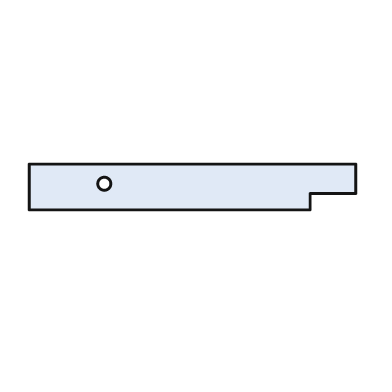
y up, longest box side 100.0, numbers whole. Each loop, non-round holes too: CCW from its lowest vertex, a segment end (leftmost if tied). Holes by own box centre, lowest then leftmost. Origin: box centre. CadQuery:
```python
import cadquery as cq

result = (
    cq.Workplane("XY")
    .moveTo(-50.0, -7.0)
    .lineTo(36.0, -7.0)
    .lineTo(36.0, -2.0)
    .lineTo(50.0, -2.0)
    .lineTo(50.0, 7.0)
    .lineTo(-50.0, 7.0)
    .close()
    .moveTo(-27.0, 1.0)
    .circle(2.0)
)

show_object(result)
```